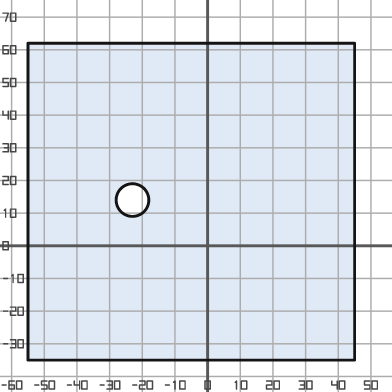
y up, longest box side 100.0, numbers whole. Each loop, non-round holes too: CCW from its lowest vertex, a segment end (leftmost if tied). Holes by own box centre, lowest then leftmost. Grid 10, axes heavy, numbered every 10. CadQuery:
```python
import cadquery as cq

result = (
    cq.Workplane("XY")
    .moveTo(-55.0, -35.0)
    .lineTo(45.0, -35.0)
    .lineTo(45.0, 62.0)
    .lineTo(-55.0, 62.0)
    .close()
    .moveTo(-23.0, 14.0)
    .circle(5.0)
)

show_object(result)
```